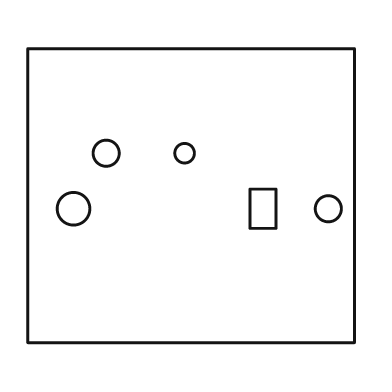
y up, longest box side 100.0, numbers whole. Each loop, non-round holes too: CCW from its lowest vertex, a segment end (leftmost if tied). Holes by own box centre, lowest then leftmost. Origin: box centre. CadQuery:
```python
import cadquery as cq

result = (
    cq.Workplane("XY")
    .moveTo(-50.0, -45.0)
    .lineTo(50.0, -45.0)
    .lineTo(50.0, 45.0)
    .lineTo(-50.0, 45.0)
    .close()
    .moveTo(-36.0, -4.0)
    .circle(5.0)
    .moveTo(18.0, -10.0)
    .lineTo(26.0, -10.0)
    .lineTo(26.0, 2.0)
    .lineTo(18.0, 2.0)
    .close()
    .moveTo(42.0, -4.0)
    .circle(4.0)
    .moveTo(-26.0, 13.0)
    .circle(4.0)
    .moveTo(-2.0, 13.0)
    .circle(3.0)
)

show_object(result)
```